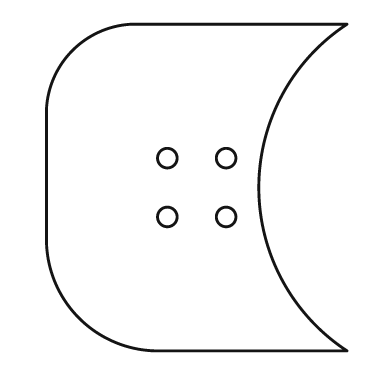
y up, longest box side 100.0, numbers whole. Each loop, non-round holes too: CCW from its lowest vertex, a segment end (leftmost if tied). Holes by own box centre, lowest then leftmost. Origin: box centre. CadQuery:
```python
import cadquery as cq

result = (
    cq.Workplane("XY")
    .moveTo(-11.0, -50.0)
    .lineTo(46.0, -50.0)
    .threePointArc((19.0, 0.0), (46.0, 50.0))
    .lineTo(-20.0, 50.0)
    .threePointArc((-38.0, 42.0), (-46.0, 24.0))
    .lineTo(-46.0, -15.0)
    .threePointArc((-36.0, -40.0), (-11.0, -50.0))
    .close()
    .moveTo(-9.0, -9.0)
    .circle(3.0)
    .moveTo(9.0, -9.0)
    .circle(3.0)
    .moveTo(-9.0, 9.0)
    .circle(3.0)
    .moveTo(9.0, 9.0)
    .circle(3.0)
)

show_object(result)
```